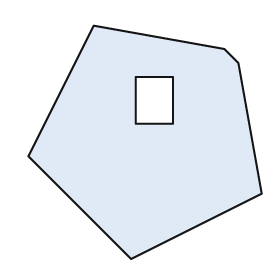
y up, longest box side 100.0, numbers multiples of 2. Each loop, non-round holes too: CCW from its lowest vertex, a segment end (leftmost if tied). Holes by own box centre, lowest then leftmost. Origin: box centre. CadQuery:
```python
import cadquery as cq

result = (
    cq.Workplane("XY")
    .moveTo(-6.0, -50.0)
    .lineTo(50.0, -22.0)
    .lineTo(40.0, 34.0)
    .lineTo(34.0, 40.0)
    .lineTo(-22.0, 50.0)
    .lineTo(-50.0, -6.0)
    .close()
    .moveTo(-4.0, 8.0)
    .lineTo(12.0, 8.0)
    .lineTo(12.0, 28.0)
    .lineTo(-4.0, 28.0)
    .close()
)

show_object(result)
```